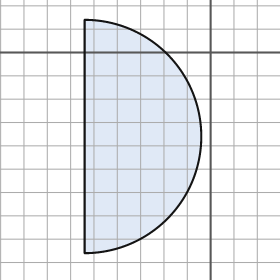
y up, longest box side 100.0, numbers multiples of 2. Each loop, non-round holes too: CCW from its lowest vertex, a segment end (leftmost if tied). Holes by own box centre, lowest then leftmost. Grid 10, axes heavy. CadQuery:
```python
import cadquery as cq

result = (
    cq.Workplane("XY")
    .moveTo(-54.0, -86.0)
    .threePointArc((-4.0, -36.0), (-54.0, 14.0))
    .close()
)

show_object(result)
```